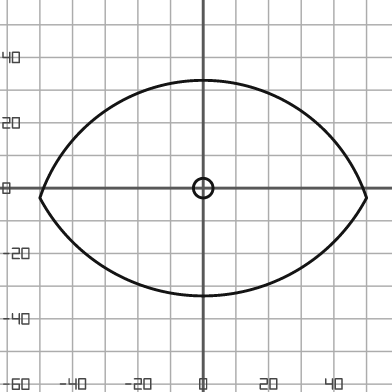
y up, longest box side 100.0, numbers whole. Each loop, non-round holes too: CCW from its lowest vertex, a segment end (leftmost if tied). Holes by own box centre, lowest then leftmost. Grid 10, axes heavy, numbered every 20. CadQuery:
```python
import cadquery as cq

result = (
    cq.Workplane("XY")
    .moveTo(-50.0, -3.0)
    .threePointArc((0.0, -33.0), (50.0, -3.0))
    .threePointArc((0.0, 33.0), (-50.0, -3.0))
    .close()
    .moveTo(0.0, 0.0)
    .circle(3.0)
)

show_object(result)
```